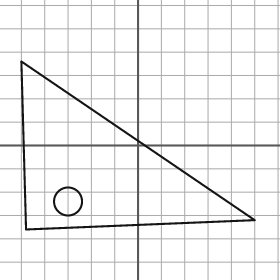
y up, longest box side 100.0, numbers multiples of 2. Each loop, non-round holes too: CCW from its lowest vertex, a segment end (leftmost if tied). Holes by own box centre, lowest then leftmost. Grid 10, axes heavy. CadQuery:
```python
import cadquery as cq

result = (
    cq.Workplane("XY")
    .moveTo(-48.0, -36.0)
    .lineTo(50.0, -32.0)
    .lineTo(-50.0, 36.0)
    .close()
    .moveTo(-30.0, -24.0)
    .circle(6.0)
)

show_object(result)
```